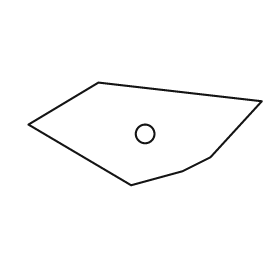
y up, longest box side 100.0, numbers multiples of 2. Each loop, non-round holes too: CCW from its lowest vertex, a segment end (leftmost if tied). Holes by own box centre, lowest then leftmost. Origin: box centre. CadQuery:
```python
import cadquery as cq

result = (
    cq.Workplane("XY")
    .moveTo(-6.0, -22.0)
    .lineTo(16.0, -16.0)
    .lineTo(28.0, -10.0)
    .lineTo(50.0, 14.0)
    .lineTo(-20.0, 22.0)
    .lineTo(-50.0, 4.0)
    .close()
    .moveTo(0.0, 0.0)
    .circle(4.0)
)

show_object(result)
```